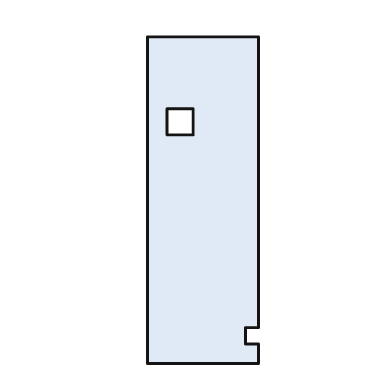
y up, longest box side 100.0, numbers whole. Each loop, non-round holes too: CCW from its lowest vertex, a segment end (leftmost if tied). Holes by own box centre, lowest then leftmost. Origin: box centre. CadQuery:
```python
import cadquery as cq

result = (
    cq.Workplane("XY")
    .moveTo(-17.0, -50.0)
    .lineTo(17.0, -50.0)
    .lineTo(17.0, -44.0)
    .lineTo(13.0, -44.0)
    .lineTo(13.0, -39.0)
    .lineTo(17.0, -39.0)
    .lineTo(17.0, 50.0)
    .lineTo(-17.0, 50.0)
    .close()
    .moveTo(-11.0, 20.0)
    .lineTo(-3.0, 20.0)
    .lineTo(-3.0, 28.0)
    .lineTo(-11.0, 28.0)
    .close()
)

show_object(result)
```